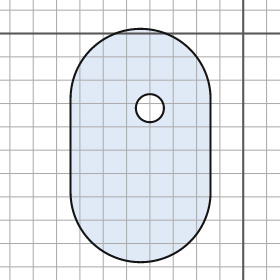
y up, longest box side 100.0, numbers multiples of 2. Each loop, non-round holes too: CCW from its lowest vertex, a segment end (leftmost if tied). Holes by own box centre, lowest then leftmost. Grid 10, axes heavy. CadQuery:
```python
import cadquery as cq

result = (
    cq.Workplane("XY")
    .moveTo(-74.0, -68.0)
    .threePointArc((-44.0, -98.0), (-14.0, -68.0))
    .lineTo(-14.0, -28.0)
    .threePointArc((-44.0, 2.0), (-74.0, -28.0))
    .close()
    .moveTo(-40.0, -32.0)
    .circle(6.0)
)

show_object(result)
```